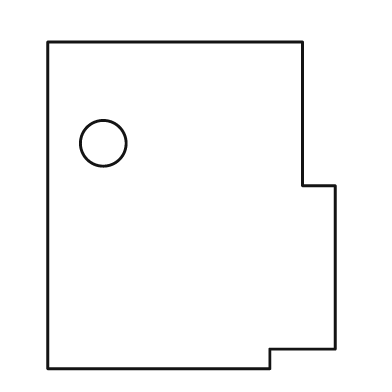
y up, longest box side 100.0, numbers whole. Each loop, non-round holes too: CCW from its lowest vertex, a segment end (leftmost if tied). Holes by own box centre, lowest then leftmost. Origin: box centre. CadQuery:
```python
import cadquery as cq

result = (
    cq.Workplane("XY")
    .moveTo(-44.0, -50.0)
    .lineTo(24.0, -50.0)
    .lineTo(24.0, -44.0)
    .lineTo(44.0, -44.0)
    .lineTo(44.0, 6.0)
    .lineTo(34.0, 6.0)
    .lineTo(34.0, 50.0)
    .lineTo(-44.0, 50.0)
    .close()
    .moveTo(-27.0, 19.0)
    .circle(7.0)
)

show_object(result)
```